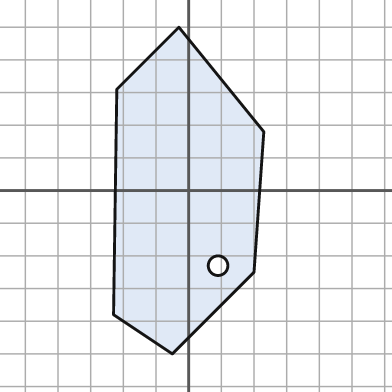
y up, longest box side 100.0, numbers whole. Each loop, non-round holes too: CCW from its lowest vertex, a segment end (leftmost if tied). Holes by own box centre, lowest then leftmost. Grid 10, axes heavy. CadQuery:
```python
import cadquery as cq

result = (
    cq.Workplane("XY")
    .moveTo(-5.0, -50.0)
    .lineTo(20.0, -25.0)
    .lineTo(23.0, 18.0)
    .lineTo(-3.0, 50.0)
    .lineTo(-22.0, 31.0)
    .lineTo(-23.0, -38.0)
    .close()
    .moveTo(9.0, -23.0)
    .circle(3.0)
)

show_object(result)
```